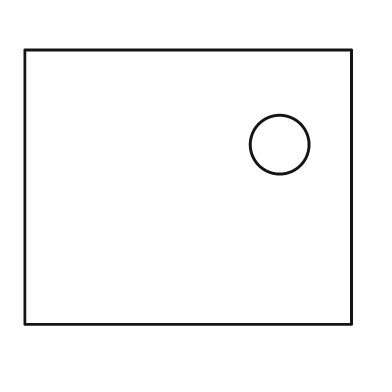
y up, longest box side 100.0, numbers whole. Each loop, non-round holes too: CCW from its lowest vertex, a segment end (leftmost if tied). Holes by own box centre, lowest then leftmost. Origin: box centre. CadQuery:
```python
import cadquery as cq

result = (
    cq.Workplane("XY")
    .moveTo(-50.0, -42.0)
    .lineTo(50.0, -42.0)
    .lineTo(50.0, 42.0)
    .lineTo(-50.0, 42.0)
    .close()
    .moveTo(28.0, 13.0)
    .circle(9.0)
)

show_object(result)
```